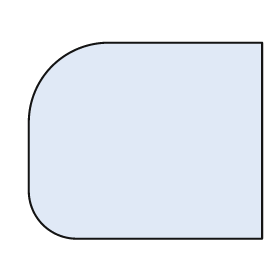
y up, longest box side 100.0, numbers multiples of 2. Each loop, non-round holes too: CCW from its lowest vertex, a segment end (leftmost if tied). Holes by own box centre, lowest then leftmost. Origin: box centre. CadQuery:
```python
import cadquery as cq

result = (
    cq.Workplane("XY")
    .moveTo(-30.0, -42.0)
    .lineTo(50.0, -42.0)
    .lineTo(50.0, 42.0)
    .lineTo(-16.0, 42.0)
    .threePointArc((-40.0, 32.0), (-50.0, 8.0))
    .lineTo(-50.0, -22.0)
    .threePointArc((-44.0, -36.0), (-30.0, -42.0))
    .close()
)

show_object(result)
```